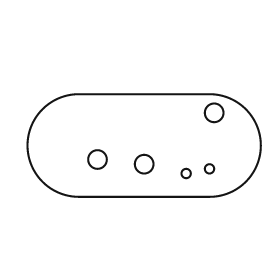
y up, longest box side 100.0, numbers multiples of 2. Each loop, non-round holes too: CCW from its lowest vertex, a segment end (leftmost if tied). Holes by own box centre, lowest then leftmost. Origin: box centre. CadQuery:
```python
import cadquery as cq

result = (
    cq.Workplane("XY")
    .moveTo(-28.0, -22.0)
    .lineTo(28.0, -22.0)
    .threePointArc((50.0, 0.0), (28.0, 22.0))
    .lineTo(-28.0, 22.0)
    .threePointArc((-50.0, 0.0), (-28.0, -22.0))
    .close()
    .moveTo(18.0, -12.0)
    .circle(2.0)
    .moveTo(28.0, -10.0)
    .circle(2.0)
    .moveTo(0.0, -8.0)
    .circle(4.0)
    .moveTo(-20.0, -6.0)
    .circle(4.0)
    .moveTo(30.0, 14.0)
    .circle(4.0)
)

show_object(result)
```